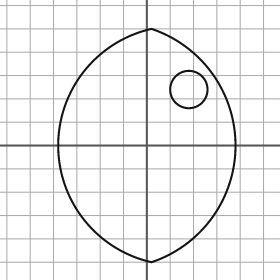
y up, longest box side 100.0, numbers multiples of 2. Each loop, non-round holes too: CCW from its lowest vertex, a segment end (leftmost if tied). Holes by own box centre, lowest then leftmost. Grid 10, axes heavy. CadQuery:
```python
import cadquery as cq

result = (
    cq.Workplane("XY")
    .moveTo(2.0, -50.0)
    .threePointArc((38.0, 0.0), (2.0, 50.0))
    .threePointArc((-38.0, 0.0), (2.0, -50.0))
    .close()
    .moveTo(18.0, 24.0)
    .circle(8.0)
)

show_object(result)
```